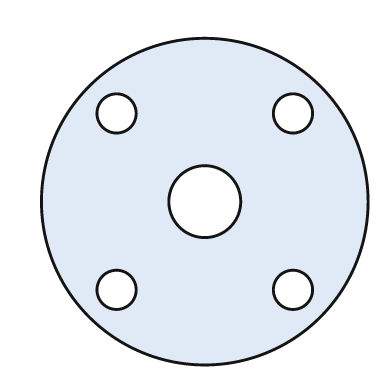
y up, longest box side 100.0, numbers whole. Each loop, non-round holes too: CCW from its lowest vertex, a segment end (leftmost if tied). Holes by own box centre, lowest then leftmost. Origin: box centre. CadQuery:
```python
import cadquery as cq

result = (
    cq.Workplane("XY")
    .moveTo(0.0, 0.0)
    .circle(50.0)
    .moveTo(-27.0, -27.0)
    .circle(6.0)
    .moveTo(27.0, -27.0)
    .circle(6.0)
    .moveTo(0.0, 0.0)
    .circle(11.0)
    .moveTo(-27.0, 27.0)
    .circle(6.0)
    .moveTo(27.0, 27.0)
    .circle(6.0)
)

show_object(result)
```